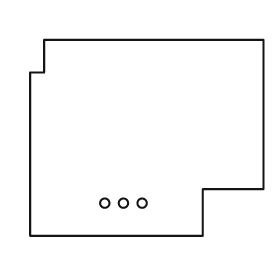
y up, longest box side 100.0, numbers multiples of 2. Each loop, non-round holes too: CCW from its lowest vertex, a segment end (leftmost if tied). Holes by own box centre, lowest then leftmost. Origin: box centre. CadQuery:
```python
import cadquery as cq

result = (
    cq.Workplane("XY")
    .moveTo(-50.0, -42.0)
    .lineTo(24.0, -42.0)
    .lineTo(24.0, -22.0)
    .lineTo(50.0, -22.0)
    .lineTo(50.0, 42.0)
    .lineTo(-44.0, 42.0)
    .lineTo(-44.0, 28.0)
    .lineTo(-50.0, 28.0)
    .close()
    .moveTo(-18.0, -28.0)
    .circle(2.0)
    .moveTo(-10.0, -28.0)
    .circle(2.0)
    .moveTo(-2.0, -28.0)
    .circle(2.0)
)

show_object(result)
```